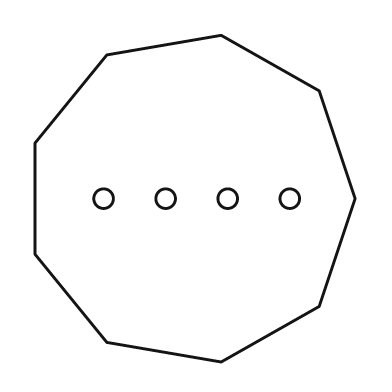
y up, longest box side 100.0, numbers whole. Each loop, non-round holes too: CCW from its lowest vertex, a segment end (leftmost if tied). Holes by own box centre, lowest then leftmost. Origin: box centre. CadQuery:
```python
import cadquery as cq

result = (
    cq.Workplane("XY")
    .moveTo(8.0, -50.0)
    .lineTo(38.0, -33.0)
    .lineTo(49.0, 0.0)
    .lineTo(38.0, 33.0)
    .lineTo(8.0, 50.0)
    .lineTo(-27.0, 44.0)
    .lineTo(-49.0, 17.0)
    .lineTo(-49.0, -17.0)
    .lineTo(-27.0, -44.0)
    .close()
    .moveTo(-28.0, 0.0)
    .circle(3.0)
    .moveTo(-9.0, 0.0)
    .circle(3.0)
    .moveTo(10.0, 0.0)
    .circle(3.0)
    .moveTo(29.0, 0.0)
    .circle(3.0)
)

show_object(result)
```